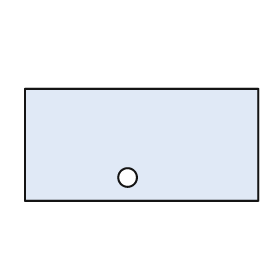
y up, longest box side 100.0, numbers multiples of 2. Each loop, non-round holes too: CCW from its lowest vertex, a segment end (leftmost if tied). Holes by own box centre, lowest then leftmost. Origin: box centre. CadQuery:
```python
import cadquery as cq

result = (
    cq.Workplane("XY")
    .moveTo(-50.0, -24.0)
    .lineTo(50.0, -24.0)
    .lineTo(50.0, 24.0)
    .lineTo(-50.0, 24.0)
    .close()
    .moveTo(-6.0, -14.0)
    .circle(4.0)
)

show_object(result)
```